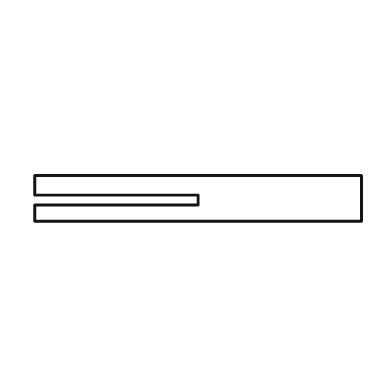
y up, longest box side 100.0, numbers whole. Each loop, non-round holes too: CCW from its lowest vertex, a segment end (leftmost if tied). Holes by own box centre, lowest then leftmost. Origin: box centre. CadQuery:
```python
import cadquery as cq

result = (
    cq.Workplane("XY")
    .moveTo(-50.0, -7.0)
    .lineTo(50.0, -7.0)
    .lineTo(50.0, 7.0)
    .lineTo(-50.0, 7.0)
    .lineTo(-50.0, 1.0)
    .lineTo(0.0, 1.0)
    .lineTo(0.0, -2.0)
    .lineTo(-50.0, -2.0)
    .close()
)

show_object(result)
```